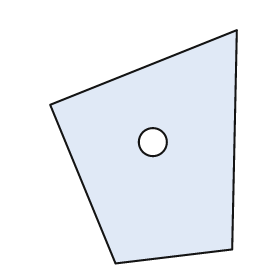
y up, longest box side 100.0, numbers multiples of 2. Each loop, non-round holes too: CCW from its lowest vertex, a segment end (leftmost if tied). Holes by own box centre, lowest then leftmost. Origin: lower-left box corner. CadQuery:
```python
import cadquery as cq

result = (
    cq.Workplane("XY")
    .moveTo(28.0, 0.0)
    .lineTo(78.0, 6.0)
    .lineTo(80.0, 100.0)
    .lineTo(0.0, 68.0)
    .close()
    .moveTo(44.0, 52.0)
    .circle(6.0)
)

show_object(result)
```